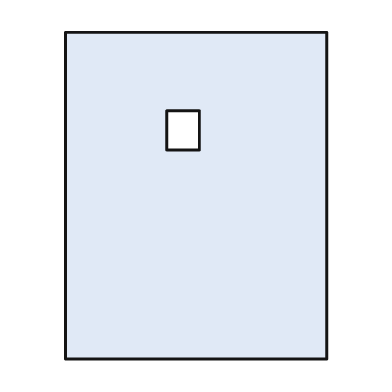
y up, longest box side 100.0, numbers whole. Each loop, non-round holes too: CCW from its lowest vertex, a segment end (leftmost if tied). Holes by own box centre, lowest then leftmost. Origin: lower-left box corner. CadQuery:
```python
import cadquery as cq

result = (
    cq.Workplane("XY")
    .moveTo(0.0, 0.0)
    .lineTo(80.0, 0.0)
    .lineTo(80.0, 100.0)
    .lineTo(0.0, 100.0)
    .close()
    .moveTo(31.0, 64.0)
    .lineTo(41.0, 64.0)
    .lineTo(41.0, 76.0)
    .lineTo(31.0, 76.0)
    .close()
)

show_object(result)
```